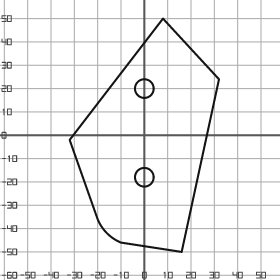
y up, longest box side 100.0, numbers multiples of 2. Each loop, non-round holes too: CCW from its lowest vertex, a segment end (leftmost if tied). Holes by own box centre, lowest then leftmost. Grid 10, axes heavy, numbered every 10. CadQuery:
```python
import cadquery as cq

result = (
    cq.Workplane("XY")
    .moveTo(16.0, -50.0)
    .lineTo(32.0, 24.0)
    .lineTo(8.0, 50.0)
    .lineTo(-32.0, -2.0)
    .lineTo(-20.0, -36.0)
    .threePointArc((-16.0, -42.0), (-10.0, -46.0))
    .close()
    .moveTo(0.0, -18.0)
    .circle(4.0)
    .moveTo(0.0, 20.0)
    .circle(4.0)
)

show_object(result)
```